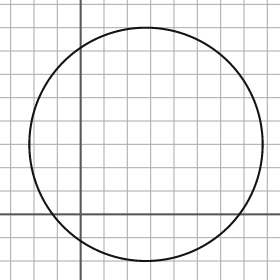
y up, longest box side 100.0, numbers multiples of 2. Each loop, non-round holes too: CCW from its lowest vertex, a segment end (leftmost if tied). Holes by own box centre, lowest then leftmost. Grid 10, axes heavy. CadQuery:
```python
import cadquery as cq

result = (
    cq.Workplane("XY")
    .moveTo(28.0, 30.0)
    .circle(50.0)
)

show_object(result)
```